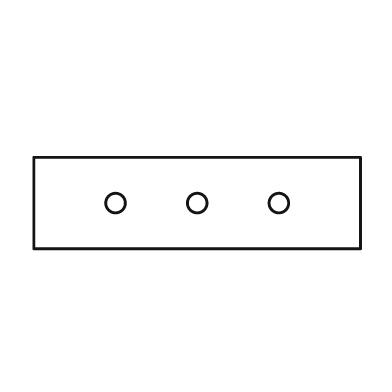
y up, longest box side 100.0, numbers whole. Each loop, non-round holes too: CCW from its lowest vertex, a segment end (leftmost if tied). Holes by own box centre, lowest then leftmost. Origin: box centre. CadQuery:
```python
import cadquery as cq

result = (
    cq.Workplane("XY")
    .moveTo(-50.0, -14.0)
    .lineTo(50.0, -14.0)
    .lineTo(50.0, 14.0)
    .lineTo(-50.0, 14.0)
    .close()
    .moveTo(-25.0, 0.0)
    .circle(3.0)
    .moveTo(0.0, 0.0)
    .circle(3.0)
    .moveTo(25.0, 0.0)
    .circle(3.0)
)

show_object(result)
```